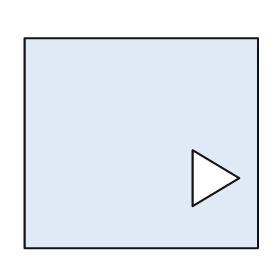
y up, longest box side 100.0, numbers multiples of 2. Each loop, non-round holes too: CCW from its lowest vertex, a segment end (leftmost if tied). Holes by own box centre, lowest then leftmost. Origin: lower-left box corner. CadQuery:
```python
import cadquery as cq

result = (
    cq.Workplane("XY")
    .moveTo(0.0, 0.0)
    .lineTo(100.0, 0.0)
    .lineTo(100.0, 90.0)
    .lineTo(0.0, 90.0)
    .close()
    .moveTo(72.0, 18.0)
    .lineTo(92.0, 30.0)
    .lineTo(72.0, 42.0)
    .close()
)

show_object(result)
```